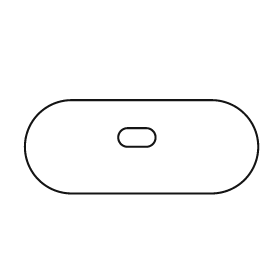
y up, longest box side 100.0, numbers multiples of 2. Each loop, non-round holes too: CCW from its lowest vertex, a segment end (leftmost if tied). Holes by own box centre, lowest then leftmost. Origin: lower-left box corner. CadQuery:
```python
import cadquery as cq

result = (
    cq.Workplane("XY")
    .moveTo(20.0, 0.0)
    .lineTo(80.0, 0.0)
    .threePointArc((100.0, 20.0), (80.0, 40.0))
    .lineTo(20.0, 40.0)
    .threePointArc((0.0, 20.0), (20.0, 0.0))
    .close()
    .moveTo(44.0, 20.0)
    .lineTo(52.0, 20.0)
    .threePointArc((56.0, 24.0), (52.0, 28.0))
    .lineTo(44.0, 28.0)
    .threePointArc((40.0, 24.0), (44.0, 20.0))
    .close()
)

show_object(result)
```